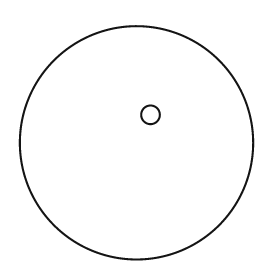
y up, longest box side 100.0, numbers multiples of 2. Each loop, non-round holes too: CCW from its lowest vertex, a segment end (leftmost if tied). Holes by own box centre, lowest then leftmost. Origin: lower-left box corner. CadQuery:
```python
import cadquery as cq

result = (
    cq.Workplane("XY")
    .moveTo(50.0, 50.0)
    .circle(50.0)
    .moveTo(56.0, 62.0)
    .circle(4.0)
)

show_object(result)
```